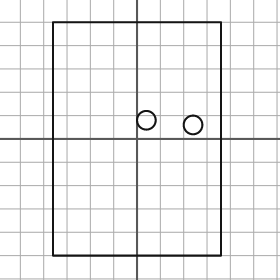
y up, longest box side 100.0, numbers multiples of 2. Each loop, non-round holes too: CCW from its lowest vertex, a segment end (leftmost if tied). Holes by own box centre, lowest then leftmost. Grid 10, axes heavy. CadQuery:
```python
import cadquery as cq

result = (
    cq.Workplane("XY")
    .moveTo(-36.0, -50.0)
    .lineTo(36.0, -50.0)
    .lineTo(36.0, 50.0)
    .lineTo(-36.0, 50.0)
    .close()
    .moveTo(24.0, 6.0)
    .circle(4.0)
    .moveTo(4.0, 8.0)
    .circle(4.0)
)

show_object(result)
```